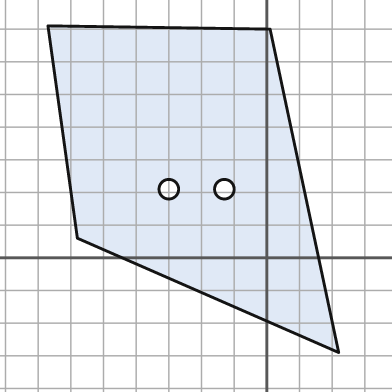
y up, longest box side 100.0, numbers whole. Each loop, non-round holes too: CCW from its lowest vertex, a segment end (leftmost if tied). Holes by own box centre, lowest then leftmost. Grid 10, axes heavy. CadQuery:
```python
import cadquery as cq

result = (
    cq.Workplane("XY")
    .moveTo(22.0, -29.0)
    .lineTo(1.0, 70.0)
    .lineTo(-67.0, 71.0)
    .lineTo(-58.0, 6.0)
    .close()
    .moveTo(-30.0, 21.0)
    .circle(3.0)
    .moveTo(-13.0, 21.0)
    .circle(3.0)
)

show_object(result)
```